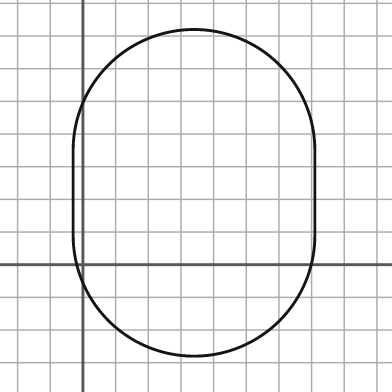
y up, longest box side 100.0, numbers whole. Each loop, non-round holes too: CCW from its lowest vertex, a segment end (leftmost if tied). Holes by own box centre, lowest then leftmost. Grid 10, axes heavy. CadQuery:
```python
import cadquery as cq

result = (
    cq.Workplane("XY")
    .moveTo(-3.0, 9.0)
    .threePointArc((34.0, -28.0), (71.0, 9.0))
    .lineTo(71.0, 35.0)
    .threePointArc((34.0, 72.0), (-3.0, 35.0))
    .close()
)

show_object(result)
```